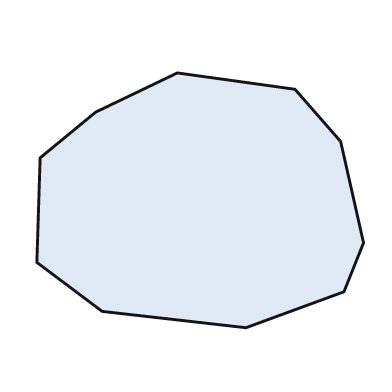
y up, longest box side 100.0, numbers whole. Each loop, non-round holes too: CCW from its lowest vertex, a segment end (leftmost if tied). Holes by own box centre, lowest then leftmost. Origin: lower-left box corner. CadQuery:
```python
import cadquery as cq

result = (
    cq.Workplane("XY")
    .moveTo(64.0, 0.0)
    .lineTo(94.0, 11.0)
    .lineTo(100.0, 26.0)
    .lineTo(93.0, 57.0)
    .lineTo(79.0, 73.0)
    .lineTo(43.0, 78.0)
    .lineTo(18.0, 66.0)
    .lineTo(1.0, 52.0)
    .lineTo(0.0, 20.0)
    .lineTo(20.0, 5.0)
    .close()
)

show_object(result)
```